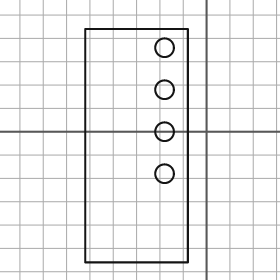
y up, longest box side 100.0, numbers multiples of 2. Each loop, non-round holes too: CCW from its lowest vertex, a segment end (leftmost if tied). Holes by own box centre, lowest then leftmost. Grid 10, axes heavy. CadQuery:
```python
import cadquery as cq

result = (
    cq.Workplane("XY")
    .moveTo(-52.0, -56.0)
    .lineTo(-8.0, -56.0)
    .lineTo(-8.0, 44.0)
    .lineTo(-52.0, 44.0)
    .close()
    .moveTo(-18.0, -18.0)
    .circle(4.0)
    .moveTo(-18.0, 0.0)
    .circle(4.0)
    .moveTo(-18.0, 18.0)
    .circle(4.0)
    .moveTo(-18.0, 36.0)
    .circle(4.0)
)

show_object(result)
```